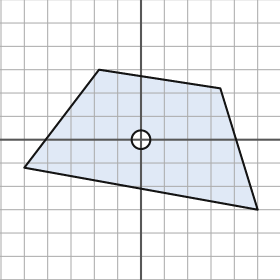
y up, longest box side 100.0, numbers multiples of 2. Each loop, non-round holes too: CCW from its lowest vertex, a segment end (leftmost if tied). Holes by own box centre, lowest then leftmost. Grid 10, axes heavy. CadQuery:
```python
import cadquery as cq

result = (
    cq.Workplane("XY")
    .moveTo(50.0, -30.0)
    .lineTo(34.0, 22.0)
    .lineTo(-18.0, 30.0)
    .lineTo(-50.0, -12.0)
    .close()
    .moveTo(0.0, 0.0)
    .circle(4.0)
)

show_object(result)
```